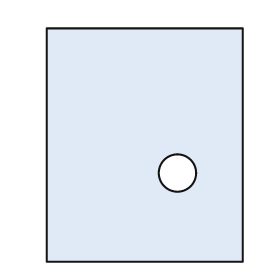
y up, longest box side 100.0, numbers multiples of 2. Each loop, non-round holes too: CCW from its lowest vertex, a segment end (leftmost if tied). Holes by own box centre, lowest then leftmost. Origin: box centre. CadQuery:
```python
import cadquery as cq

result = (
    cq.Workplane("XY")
    .moveTo(-42.0, -50.0)
    .lineTo(42.0, -50.0)
    .lineTo(42.0, 50.0)
    .lineTo(-42.0, 50.0)
    .close()
    .moveTo(14.0, -12.0)
    .circle(8.0)
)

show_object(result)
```